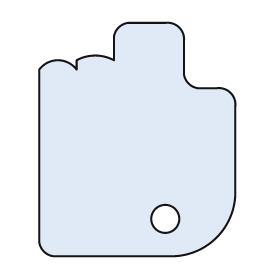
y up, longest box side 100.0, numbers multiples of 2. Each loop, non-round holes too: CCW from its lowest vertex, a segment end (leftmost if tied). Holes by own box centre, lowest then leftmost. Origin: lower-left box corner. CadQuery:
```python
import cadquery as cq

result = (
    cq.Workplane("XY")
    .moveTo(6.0, 0.0)
    .lineTo(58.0, 0.0)
    .threePointArc((76.0, 8.0), (84.0, 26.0))
    .lineTo(84.0, 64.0)
    .threePointArc((82.0, 70.0), (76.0, 72.0))
    .lineTo(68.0, 72.0)
    .threePointArc((64.0, 74.0), (62.0, 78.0))
    .lineTo(62.0, 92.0)
    .threePointArc((60.0, 98.0), (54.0, 100.0))
    .lineTo(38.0, 100.0)
    .threePointArc((34.0, 98.0), (32.0, 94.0))
    .lineTo(32.0, 84.0)
    .threePointArc((24.0, 86.0), (16.0, 84.0))
    .lineTo(16.0, 80.0)
    .threePointArc((8.0, 84.0), (0.0, 80.0))
    .lineTo(0.0, 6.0)
    .threePointArc((2.0, 2.0), (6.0, 0.0))
    .close()
    .moveTo(54.0, 16.0)
    .circle(6.0)
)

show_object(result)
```